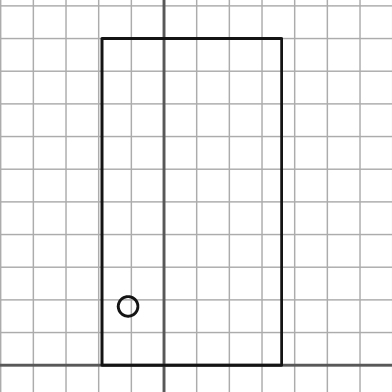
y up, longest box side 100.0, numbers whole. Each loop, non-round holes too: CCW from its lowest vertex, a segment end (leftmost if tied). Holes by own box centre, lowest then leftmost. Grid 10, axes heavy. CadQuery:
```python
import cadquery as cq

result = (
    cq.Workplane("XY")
    .moveTo(-19.0, 0.0)
    .lineTo(36.0, 0.0)
    .lineTo(36.0, 100.0)
    .lineTo(-19.0, 100.0)
    .close()
    .moveTo(-11.0, 18.0)
    .circle(3.0)
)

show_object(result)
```